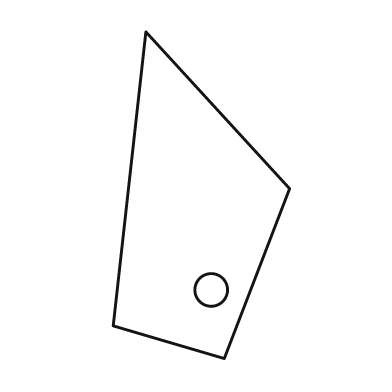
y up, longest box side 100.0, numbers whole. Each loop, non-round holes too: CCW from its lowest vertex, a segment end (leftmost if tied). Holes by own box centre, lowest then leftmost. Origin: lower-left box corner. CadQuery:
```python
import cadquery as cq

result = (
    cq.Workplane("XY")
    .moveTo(34.0, 0.0)
    .lineTo(54.0, 52.0)
    .lineTo(10.0, 100.0)
    .lineTo(0.0, 10.0)
    .close()
    .moveTo(30.0, 21.0)
    .circle(5.0)
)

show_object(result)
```